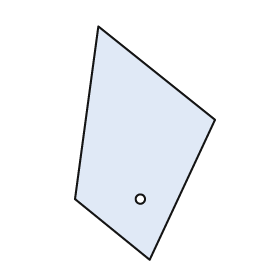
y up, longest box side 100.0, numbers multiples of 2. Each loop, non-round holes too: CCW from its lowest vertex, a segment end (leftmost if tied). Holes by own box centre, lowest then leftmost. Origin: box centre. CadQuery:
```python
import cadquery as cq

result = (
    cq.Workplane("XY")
    .moveTo(2.0, -50.0)
    .lineTo(30.0, 10.0)
    .lineTo(-20.0, 50.0)
    .lineTo(-30.0, -24.0)
    .close()
    .moveTo(-2.0, -24.0)
    .circle(2.0)
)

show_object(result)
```